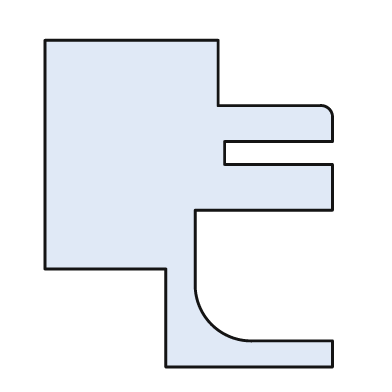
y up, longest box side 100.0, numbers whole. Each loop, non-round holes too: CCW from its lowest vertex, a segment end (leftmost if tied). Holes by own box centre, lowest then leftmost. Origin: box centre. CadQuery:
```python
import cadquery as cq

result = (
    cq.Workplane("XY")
    .moveTo(-7.0, -50.0)
    .lineTo(44.0, -50.0)
    .lineTo(44.0, -42.0)
    .lineTo(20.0, -42.0)
    .threePointArc((7.0, -37.0), (2.0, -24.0))
    .lineTo(2.0, -2.0)
    .lineTo(44.0, -2.0)
    .lineTo(44.0, 12.0)
    .lineTo(11.0, 12.0)
    .lineTo(11.0, 19.0)
    .lineTo(44.0, 19.0)
    .lineTo(44.0, 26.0)
    .threePointArc((43.0, 29.0), (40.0, 30.0))
    .lineTo(9.0, 30.0)
    .lineTo(9.0, 50.0)
    .lineTo(-44.0, 50.0)
    .lineTo(-44.0, -20.0)
    .lineTo(-7.0, -20.0)
    .close()
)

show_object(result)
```